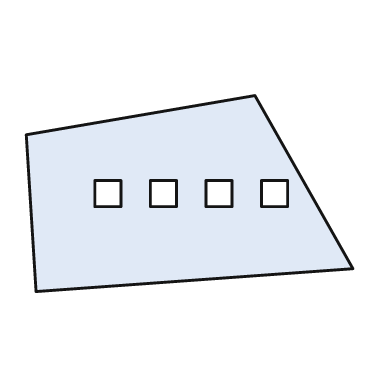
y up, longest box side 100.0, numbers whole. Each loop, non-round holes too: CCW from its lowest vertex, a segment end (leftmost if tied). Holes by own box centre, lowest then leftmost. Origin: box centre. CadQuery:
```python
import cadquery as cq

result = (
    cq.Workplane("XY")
    .moveTo(-47.0, -30.0)
    .lineTo(50.0, -23.0)
    .lineTo(20.0, 30.0)
    .lineTo(-50.0, 18.0)
    .close()
    .moveTo(-29.0, -4.0)
    .lineTo(-21.0, -4.0)
    .lineTo(-21.0, 4.0)
    .lineTo(-29.0, 4.0)
    .close()
    .moveTo(-12.0, -4.0)
    .lineTo(-4.0, -4.0)
    .lineTo(-4.0, 4.0)
    .lineTo(-12.0, 4.0)
    .close()
    .moveTo(5.0, -4.0)
    .lineTo(13.0, -4.0)
    .lineTo(13.0, 4.0)
    .lineTo(5.0, 4.0)
    .close()
    .moveTo(22.0, -4.0)
    .lineTo(30.0, -4.0)
    .lineTo(30.0, 4.0)
    .lineTo(22.0, 4.0)
    .close()
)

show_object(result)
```